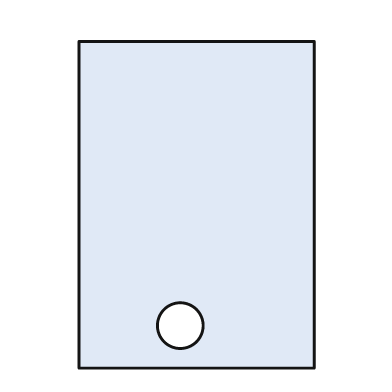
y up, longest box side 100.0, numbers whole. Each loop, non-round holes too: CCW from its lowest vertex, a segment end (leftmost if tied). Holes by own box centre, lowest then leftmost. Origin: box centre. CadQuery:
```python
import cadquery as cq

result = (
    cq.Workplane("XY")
    .moveTo(-36.0, -50.0)
    .lineTo(36.0, -50.0)
    .lineTo(36.0, 50.0)
    .lineTo(-36.0, 50.0)
    .close()
    .moveTo(-5.0, -37.0)
    .circle(7.0)
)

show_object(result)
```